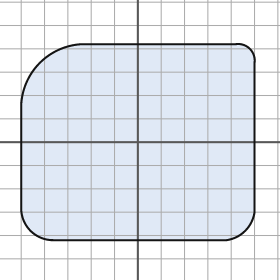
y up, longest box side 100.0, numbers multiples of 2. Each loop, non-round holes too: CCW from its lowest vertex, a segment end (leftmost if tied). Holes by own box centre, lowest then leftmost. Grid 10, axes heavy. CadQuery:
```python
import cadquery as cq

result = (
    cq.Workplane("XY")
    .moveTo(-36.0, -42.0)
    .lineTo(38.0, -42.0)
    .threePointArc((46.0, -38.0), (50.0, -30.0))
    .lineTo(50.0, 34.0)
    .threePointArc((48.0, 40.0), (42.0, 42.0))
    .lineTo(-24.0, 42.0)
    .threePointArc((-42.0, 34.0), (-50.0, 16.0))
    .lineTo(-50.0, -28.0)
    .threePointArc((-46.0, -38.0), (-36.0, -42.0))
    .close()
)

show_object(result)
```